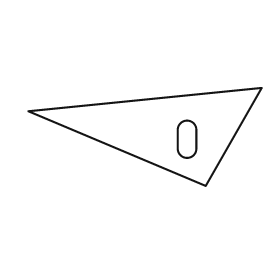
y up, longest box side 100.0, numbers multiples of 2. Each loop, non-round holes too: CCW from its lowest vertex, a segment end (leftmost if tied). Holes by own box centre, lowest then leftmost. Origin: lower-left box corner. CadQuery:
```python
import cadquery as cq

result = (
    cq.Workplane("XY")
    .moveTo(76.0, 0.0)
    .lineTo(100.0, 42.0)
    .lineTo(0.0, 32.0)
    .close()
    .moveTo(64.0, 16.0)
    .threePointArc((68.0, 12.0), (72.0, 16.0))
    .lineTo(72.0, 24.0)
    .threePointArc((68.0, 28.0), (64.0, 24.0))
    .close()
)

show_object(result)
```